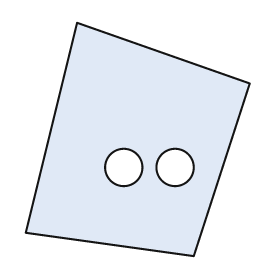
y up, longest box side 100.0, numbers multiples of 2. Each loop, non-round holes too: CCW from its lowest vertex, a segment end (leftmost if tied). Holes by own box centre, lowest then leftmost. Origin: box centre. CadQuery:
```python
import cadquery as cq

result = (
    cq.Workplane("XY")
    .moveTo(24.0, -50.0)
    .lineTo(48.0, 24.0)
    .lineTo(-26.0, 50.0)
    .lineTo(-48.0, -40.0)
    .close()
    .moveTo(-6.0, -12.0)
    .circle(8.0)
    .moveTo(16.0, -12.0)
    .circle(8.0)
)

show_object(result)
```